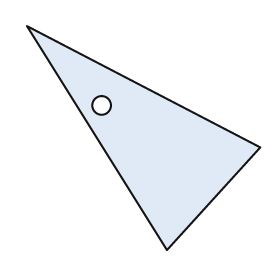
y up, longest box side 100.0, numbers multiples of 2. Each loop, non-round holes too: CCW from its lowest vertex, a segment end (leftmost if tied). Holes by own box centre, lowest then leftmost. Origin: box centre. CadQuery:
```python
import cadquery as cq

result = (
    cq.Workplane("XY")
    .moveTo(10.0, -48.0)
    .lineTo(50.0, -4.0)
    .lineTo(-50.0, 48.0)
    .close()
    .moveTo(-18.0, 14.0)
    .circle(4.0)
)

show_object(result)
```